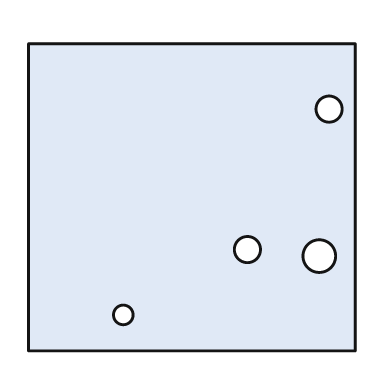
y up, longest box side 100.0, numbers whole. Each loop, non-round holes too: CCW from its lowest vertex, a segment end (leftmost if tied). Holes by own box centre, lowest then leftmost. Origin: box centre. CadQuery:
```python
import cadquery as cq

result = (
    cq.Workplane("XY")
    .moveTo(-50.0, -47.0)
    .lineTo(50.0, -47.0)
    .lineTo(50.0, 47.0)
    .lineTo(-50.0, 47.0)
    .close()
    .moveTo(-21.0, -36.0)
    .circle(3.0)
    .moveTo(39.0, -18.0)
    .circle(5.0)
    .moveTo(17.0, -16.0)
    .circle(4.0)
    .moveTo(42.0, 27.0)
    .circle(4.0)
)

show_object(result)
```